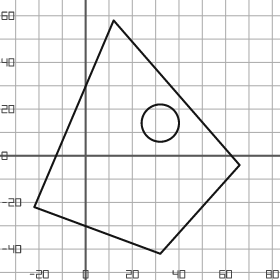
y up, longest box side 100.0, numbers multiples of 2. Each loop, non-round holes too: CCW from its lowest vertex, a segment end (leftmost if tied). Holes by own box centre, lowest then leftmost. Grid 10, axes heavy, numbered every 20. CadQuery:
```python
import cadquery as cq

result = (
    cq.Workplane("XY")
    .moveTo(32.0, -42.0)
    .lineTo(66.0, -4.0)
    .lineTo(12.0, 58.0)
    .lineTo(-22.0, -22.0)
    .close()
    .moveTo(32.0, 14.0)
    .circle(8.0)
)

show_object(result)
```